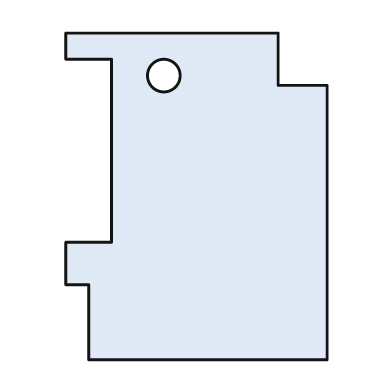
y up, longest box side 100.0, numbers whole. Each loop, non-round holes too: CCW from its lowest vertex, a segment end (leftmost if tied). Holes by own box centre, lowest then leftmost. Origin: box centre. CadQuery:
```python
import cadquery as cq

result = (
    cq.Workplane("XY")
    .moveTo(-33.0, -50.0)
    .lineTo(40.0, -50.0)
    .lineTo(40.0, 34.0)
    .lineTo(25.0, 34.0)
    .lineTo(25.0, 50.0)
    .lineTo(-40.0, 50.0)
    .lineTo(-40.0, 42.0)
    .lineTo(-26.0, 42.0)
    .lineTo(-26.0, -14.0)
    .lineTo(-40.0, -14.0)
    .lineTo(-40.0, -27.0)
    .lineTo(-33.0, -27.0)
    .close()
    .moveTo(-10.0, 37.0)
    .circle(5.0)
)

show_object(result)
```